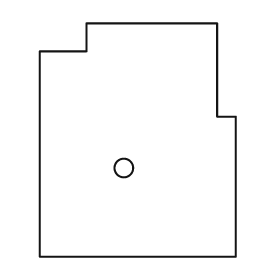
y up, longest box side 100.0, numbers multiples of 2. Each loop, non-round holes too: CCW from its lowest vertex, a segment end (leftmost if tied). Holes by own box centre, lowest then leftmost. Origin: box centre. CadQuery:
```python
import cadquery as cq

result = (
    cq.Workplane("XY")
    .moveTo(-42.0, -50.0)
    .lineTo(42.0, -50.0)
    .lineTo(42.0, 10.0)
    .lineTo(34.0, 10.0)
    .lineTo(34.0, 50.0)
    .lineTo(-22.0, 50.0)
    .lineTo(-22.0, 38.0)
    .lineTo(-42.0, 38.0)
    .close()
    .moveTo(-6.0, -12.0)
    .circle(4.0)
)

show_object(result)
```